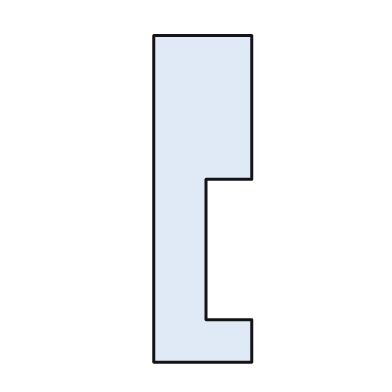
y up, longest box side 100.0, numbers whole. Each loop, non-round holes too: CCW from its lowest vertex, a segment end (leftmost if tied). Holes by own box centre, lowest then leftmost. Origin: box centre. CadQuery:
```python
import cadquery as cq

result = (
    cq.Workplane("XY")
    .moveTo(-15.0, -50.0)
    .lineTo(15.0, -50.0)
    .lineTo(15.0, -37.0)
    .lineTo(1.0, -37.0)
    .lineTo(1.0, 6.0)
    .lineTo(15.0, 6.0)
    .lineTo(15.0, 50.0)
    .lineTo(-15.0, 50.0)
    .close()
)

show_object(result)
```